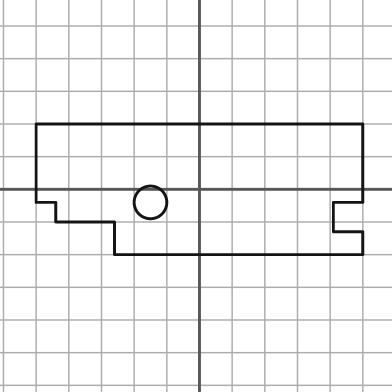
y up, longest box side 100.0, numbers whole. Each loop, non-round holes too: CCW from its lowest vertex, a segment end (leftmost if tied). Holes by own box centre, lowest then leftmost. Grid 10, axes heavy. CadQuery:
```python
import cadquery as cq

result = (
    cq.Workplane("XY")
    .moveTo(-26.0, -20.0)
    .lineTo(50.0, -20.0)
    .lineTo(50.0, -13.0)
    .lineTo(41.0, -13.0)
    .lineTo(41.0, -4.0)
    .lineTo(50.0, -4.0)
    .lineTo(50.0, 20.0)
    .lineTo(-50.0, 20.0)
    .lineTo(-50.0, -4.0)
    .lineTo(-44.0, -4.0)
    .lineTo(-44.0, -10.0)
    .lineTo(-26.0, -10.0)
    .close()
    .moveTo(-15.0, -4.0)
    .circle(5.0)
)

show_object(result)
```